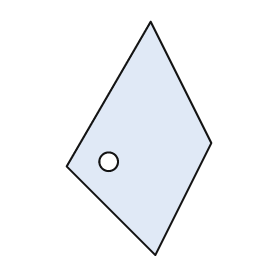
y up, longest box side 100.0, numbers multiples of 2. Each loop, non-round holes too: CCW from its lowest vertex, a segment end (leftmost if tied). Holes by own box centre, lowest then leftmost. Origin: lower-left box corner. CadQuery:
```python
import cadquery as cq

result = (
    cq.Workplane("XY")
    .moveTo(38.0, 0.0)
    .lineTo(62.0, 48.0)
    .lineTo(36.0, 100.0)
    .lineTo(0.0, 38.0)
    .close()
    .moveTo(18.0, 40.0)
    .circle(4.0)
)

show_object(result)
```